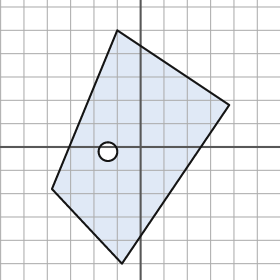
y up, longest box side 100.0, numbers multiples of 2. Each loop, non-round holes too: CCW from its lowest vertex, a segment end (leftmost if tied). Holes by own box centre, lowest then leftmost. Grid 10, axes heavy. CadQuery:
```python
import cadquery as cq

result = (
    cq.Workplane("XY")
    .moveTo(-8.0, -50.0)
    .lineTo(38.0, 18.0)
    .lineTo(-10.0, 50.0)
    .lineTo(-38.0, -18.0)
    .close()
    .moveTo(-14.0, -2.0)
    .circle(4.0)
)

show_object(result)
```